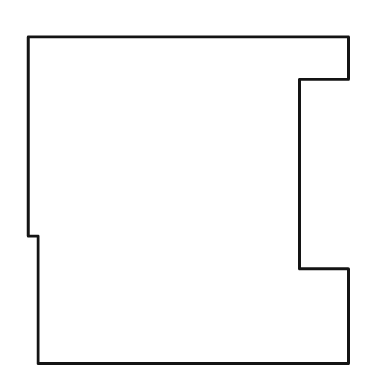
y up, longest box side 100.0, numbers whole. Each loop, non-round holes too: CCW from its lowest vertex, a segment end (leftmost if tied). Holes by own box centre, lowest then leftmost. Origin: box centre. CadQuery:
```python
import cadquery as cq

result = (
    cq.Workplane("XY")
    .moveTo(-46.0, -50.0)
    .lineTo(49.0, -50.0)
    .lineTo(49.0, -21.0)
    .lineTo(34.0, -21.0)
    .lineTo(34.0, 37.0)
    .lineTo(49.0, 37.0)
    .lineTo(49.0, 50.0)
    .lineTo(-49.0, 50.0)
    .lineTo(-49.0, -11.0)
    .lineTo(-46.0, -11.0)
    .close()
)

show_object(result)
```